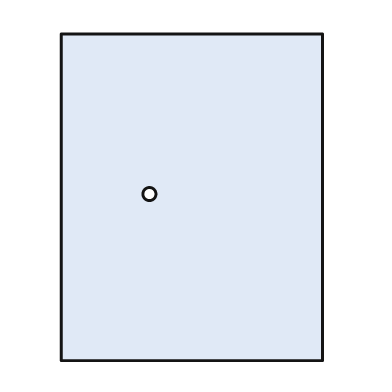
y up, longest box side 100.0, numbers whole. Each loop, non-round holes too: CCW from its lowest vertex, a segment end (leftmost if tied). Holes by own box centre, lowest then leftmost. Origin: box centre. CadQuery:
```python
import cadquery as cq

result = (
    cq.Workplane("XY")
    .moveTo(-40.0, -50.0)
    .lineTo(40.0, -50.0)
    .lineTo(40.0, 50.0)
    .lineTo(-40.0, 50.0)
    .close()
    .moveTo(-13.0, 1.0)
    .circle(2.0)
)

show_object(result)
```